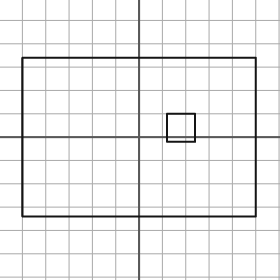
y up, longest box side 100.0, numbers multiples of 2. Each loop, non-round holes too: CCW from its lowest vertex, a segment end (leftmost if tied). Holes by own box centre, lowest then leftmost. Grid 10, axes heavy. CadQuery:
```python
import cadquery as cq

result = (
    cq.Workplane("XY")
    .moveTo(-50.0, -34.0)
    .lineTo(50.0, -34.0)
    .lineTo(50.0, 34.0)
    .lineTo(-50.0, 34.0)
    .close()
    .moveTo(12.0, -2.0)
    .lineTo(24.0, -2.0)
    .lineTo(24.0, 10.0)
    .lineTo(12.0, 10.0)
    .close()
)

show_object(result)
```